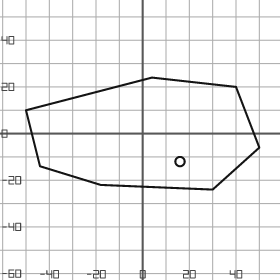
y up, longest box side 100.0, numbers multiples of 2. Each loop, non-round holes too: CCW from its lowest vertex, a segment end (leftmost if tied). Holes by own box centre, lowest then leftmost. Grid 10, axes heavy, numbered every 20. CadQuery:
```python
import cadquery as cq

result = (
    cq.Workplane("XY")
    .moveTo(30.0, -24.0)
    .lineTo(50.0, -6.0)
    .lineTo(40.0, 20.0)
    .lineTo(4.0, 24.0)
    .lineTo(-50.0, 10.0)
    .lineTo(-44.0, -14.0)
    .lineTo(-18.0, -22.0)
    .close()
    .moveTo(16.0, -12.0)
    .circle(2.0)
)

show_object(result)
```